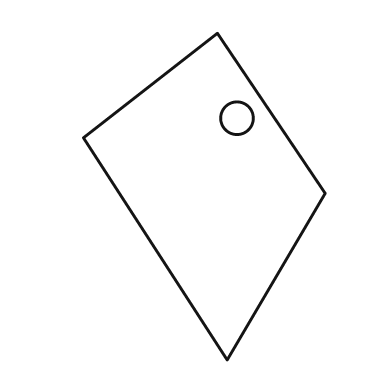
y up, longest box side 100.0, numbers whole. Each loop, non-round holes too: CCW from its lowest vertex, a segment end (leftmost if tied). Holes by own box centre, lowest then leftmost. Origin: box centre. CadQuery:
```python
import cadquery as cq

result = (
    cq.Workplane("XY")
    .moveTo(7.0, -50.0)
    .lineTo(37.0, 1.0)
    .lineTo(4.0, 50.0)
    .lineTo(-37.0, 18.0)
    .close()
    .moveTo(10.0, 24.0)
    .circle(5.0)
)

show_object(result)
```